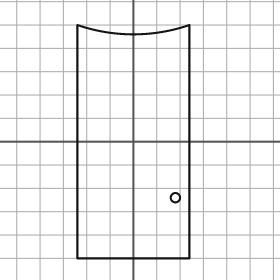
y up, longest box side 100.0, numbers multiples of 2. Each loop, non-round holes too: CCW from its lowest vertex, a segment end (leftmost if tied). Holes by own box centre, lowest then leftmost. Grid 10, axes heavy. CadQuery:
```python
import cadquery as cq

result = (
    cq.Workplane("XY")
    .moveTo(-24.0, -50.0)
    .lineTo(24.0, -50.0)
    .lineTo(24.0, 50.0)
    .threePointArc((0.0, 46.0), (-24.0, 50.0))
    .close()
    .moveTo(18.0, -24.0)
    .circle(2.0)
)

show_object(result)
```